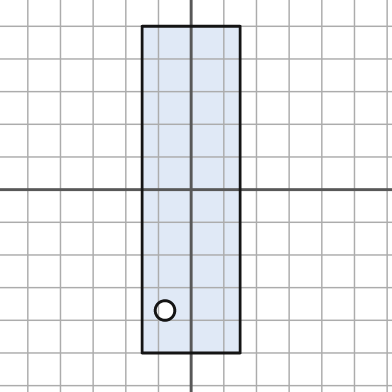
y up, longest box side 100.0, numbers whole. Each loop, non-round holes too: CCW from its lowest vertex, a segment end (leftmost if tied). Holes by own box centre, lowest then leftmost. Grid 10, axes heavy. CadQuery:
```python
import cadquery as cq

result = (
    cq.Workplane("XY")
    .moveTo(-15.0, -50.0)
    .lineTo(15.0, -50.0)
    .lineTo(15.0, 50.0)
    .lineTo(-15.0, 50.0)
    .close()
    .moveTo(-8.0, -37.0)
    .circle(3.0)
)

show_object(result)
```